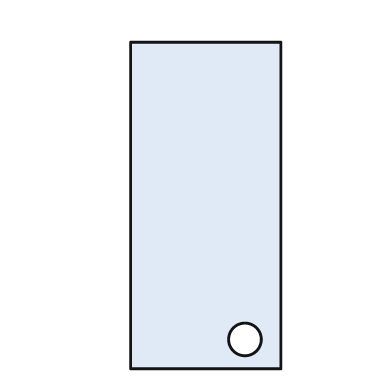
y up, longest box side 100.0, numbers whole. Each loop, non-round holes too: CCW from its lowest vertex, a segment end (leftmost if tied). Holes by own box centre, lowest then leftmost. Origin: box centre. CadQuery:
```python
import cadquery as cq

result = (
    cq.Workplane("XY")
    .moveTo(-23.0, -50.0)
    .lineTo(23.0, -50.0)
    .lineTo(23.0, 50.0)
    .lineTo(-23.0, 50.0)
    .close()
    .moveTo(12.0, -41.0)
    .circle(5.0)
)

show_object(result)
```